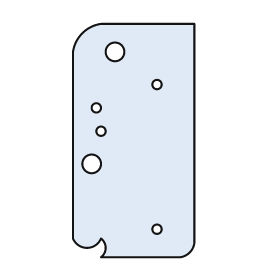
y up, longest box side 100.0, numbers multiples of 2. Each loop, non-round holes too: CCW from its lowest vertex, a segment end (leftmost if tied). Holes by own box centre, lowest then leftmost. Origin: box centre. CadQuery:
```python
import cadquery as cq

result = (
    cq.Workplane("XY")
    .moveTo(-14.0, -50.0)
    .lineTo(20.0, -50.0)
    .threePointArc((24.0, -48.0), (26.0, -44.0))
    .lineTo(26.0, 50.0)
    .lineTo(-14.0, 50.0)
    .threePointArc((-22.0, 46.0), (-26.0, 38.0))
    .lineTo(-26.0, -42.0)
    .threePointArc((-20.0, -46.0), (-14.0, -42.0))
    .threePointArc((-12.0, -46.0), (-14.0, -50.0))
    .close()
    .moveTo(10.0, -38.0)
    .circle(2.0)
    .moveTo(-18.0, -10.0)
    .circle(4.0)
    .moveTo(-14.0, 4.0)
    .circle(2.0)
    .moveTo(-16.0, 14.0)
    .circle(2.0)
    .moveTo(10.0, 24.0)
    .circle(2.0)
    .moveTo(-8.0, 38.0)
    .circle(4.0)
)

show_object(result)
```